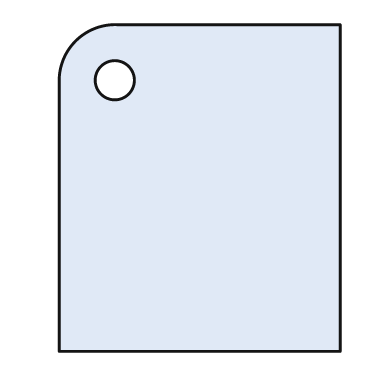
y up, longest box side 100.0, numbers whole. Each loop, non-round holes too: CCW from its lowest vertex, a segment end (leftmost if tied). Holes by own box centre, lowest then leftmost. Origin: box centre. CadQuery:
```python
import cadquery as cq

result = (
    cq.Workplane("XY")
    .moveTo(-43.0, -50.0)
    .lineTo(43.0, -50.0)
    .lineTo(43.0, 50.0)
    .lineTo(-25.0, 50.0)
    .threePointArc((-38.0, 45.0), (-43.0, 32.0))
    .close()
    .moveTo(-26.0, 33.0)
    .circle(6.0)
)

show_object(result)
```